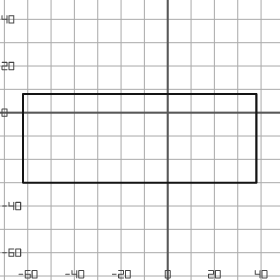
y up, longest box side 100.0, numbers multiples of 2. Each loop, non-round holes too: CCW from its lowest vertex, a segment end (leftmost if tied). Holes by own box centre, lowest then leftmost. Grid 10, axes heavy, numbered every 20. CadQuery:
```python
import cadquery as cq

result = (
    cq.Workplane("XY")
    .moveTo(-62.0, -30.0)
    .lineTo(38.0, -30.0)
    .lineTo(38.0, 8.0)
    .lineTo(-62.0, 8.0)
    .close()
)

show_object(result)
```